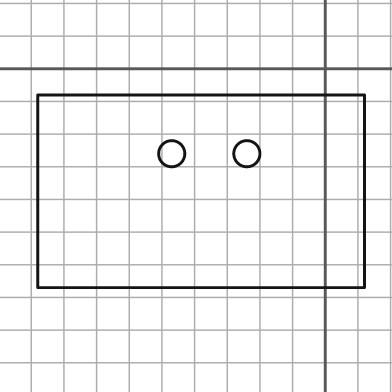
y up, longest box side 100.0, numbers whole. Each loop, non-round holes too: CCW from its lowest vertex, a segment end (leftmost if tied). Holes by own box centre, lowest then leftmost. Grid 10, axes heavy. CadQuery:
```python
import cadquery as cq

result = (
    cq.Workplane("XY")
    .moveTo(-88.0, -67.0)
    .lineTo(12.0, -67.0)
    .lineTo(12.0, -8.0)
    .lineTo(-88.0, -8.0)
    .close()
    .moveTo(-47.0, -26.0)
    .circle(4.0)
    .moveTo(-24.0, -26.0)
    .circle(4.0)
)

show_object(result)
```